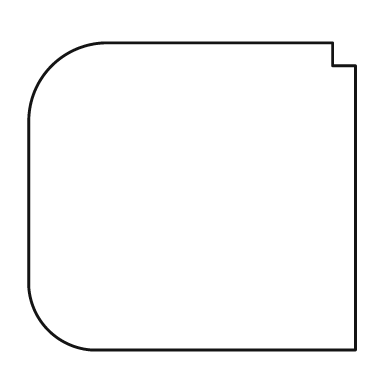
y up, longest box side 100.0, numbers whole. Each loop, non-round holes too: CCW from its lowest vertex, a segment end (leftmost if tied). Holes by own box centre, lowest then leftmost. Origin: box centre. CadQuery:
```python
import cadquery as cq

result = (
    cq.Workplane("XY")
    .moveTo(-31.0, -47.0)
    .lineTo(50.0, -47.0)
    .lineTo(50.0, 40.0)
    .lineTo(43.0, 40.0)
    .lineTo(43.0, 47.0)
    .lineTo(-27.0, 47.0)
    .threePointArc((-43.0, 40.0), (-50.0, 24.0))
    .lineTo(-50.0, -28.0)
    .threePointArc((-44.0, -41.0), (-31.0, -47.0))
    .close()
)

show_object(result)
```